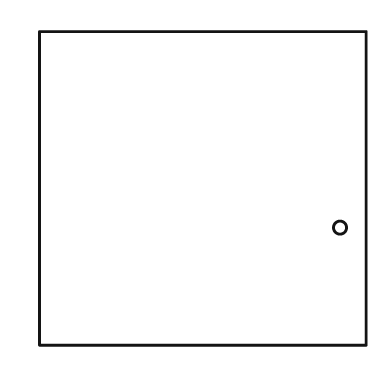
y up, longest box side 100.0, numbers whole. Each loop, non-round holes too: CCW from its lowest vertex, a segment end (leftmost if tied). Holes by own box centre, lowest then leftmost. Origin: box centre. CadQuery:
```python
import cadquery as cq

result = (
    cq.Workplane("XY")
    .moveTo(-50.0, -48.0)
    .lineTo(50.0, -48.0)
    .lineTo(50.0, 48.0)
    .lineTo(-50.0, 48.0)
    .close()
    .moveTo(42.0, -12.0)
    .circle(2.0)
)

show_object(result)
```